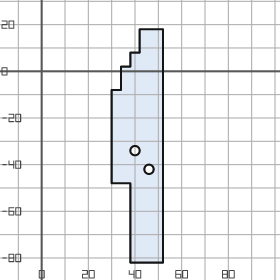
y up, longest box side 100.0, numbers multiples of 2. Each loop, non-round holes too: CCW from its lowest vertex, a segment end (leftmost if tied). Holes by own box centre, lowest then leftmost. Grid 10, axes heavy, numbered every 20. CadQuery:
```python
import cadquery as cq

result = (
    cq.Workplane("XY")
    .moveTo(38.0, -82.0)
    .lineTo(52.0, -82.0)
    .lineTo(52.0, 18.0)
    .lineTo(42.0, 18.0)
    .lineTo(42.0, 8.0)
    .lineTo(38.0, 8.0)
    .lineTo(38.0, 2.0)
    .lineTo(34.0, 2.0)
    .lineTo(34.0, -8.0)
    .lineTo(30.0, -8.0)
    .lineTo(30.0, -48.0)
    .lineTo(38.0, -48.0)
    .close()
    .moveTo(46.0, -42.0)
    .circle(2.0)
    .moveTo(40.0, -34.0)
    .circle(2.0)
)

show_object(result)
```